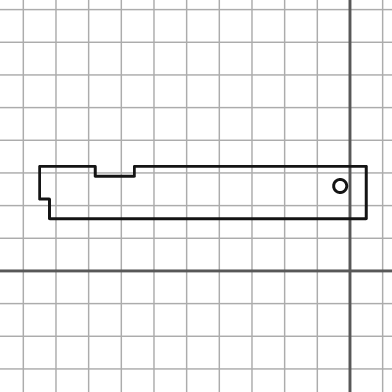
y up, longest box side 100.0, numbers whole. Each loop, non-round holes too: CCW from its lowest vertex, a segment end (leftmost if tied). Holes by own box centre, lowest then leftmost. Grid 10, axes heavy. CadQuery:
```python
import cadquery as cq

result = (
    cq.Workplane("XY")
    .moveTo(-92.0, 16.0)
    .lineTo(5.0, 16.0)
    .lineTo(5.0, 32.0)
    .lineTo(-66.0, 32.0)
    .lineTo(-66.0, 29.0)
    .lineTo(-78.0, 29.0)
    .lineTo(-78.0, 32.0)
    .lineTo(-95.0, 32.0)
    .lineTo(-95.0, 22.0)
    .lineTo(-92.0, 22.0)
    .close()
    .moveTo(-3.0, 26.0)
    .circle(2.0)
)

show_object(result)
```